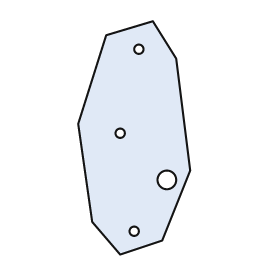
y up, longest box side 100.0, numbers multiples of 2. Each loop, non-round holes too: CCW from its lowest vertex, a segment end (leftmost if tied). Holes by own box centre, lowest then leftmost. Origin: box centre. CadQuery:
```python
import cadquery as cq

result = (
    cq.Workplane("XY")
    .moveTo(-6.0, -50.0)
    .lineTo(12.0, -44.0)
    .lineTo(24.0, -14.0)
    .lineTo(18.0, 34.0)
    .lineTo(8.0, 50.0)
    .lineTo(-12.0, 44.0)
    .lineTo(-24.0, 6.0)
    .lineTo(-18.0, -36.0)
    .close()
    .moveTo(0.0, -40.0)
    .circle(2.0)
    .moveTo(14.0, -18.0)
    .circle(4.0)
    .moveTo(-6.0, 2.0)
    .circle(2.0)
    .moveTo(2.0, 38.0)
    .circle(2.0)
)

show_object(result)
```